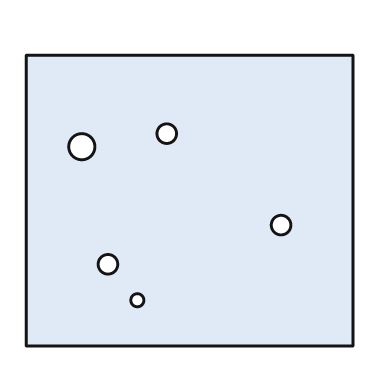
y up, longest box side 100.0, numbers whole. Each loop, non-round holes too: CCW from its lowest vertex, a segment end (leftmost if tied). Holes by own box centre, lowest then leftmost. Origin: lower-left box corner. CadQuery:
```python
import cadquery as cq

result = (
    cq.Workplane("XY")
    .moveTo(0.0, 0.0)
    .lineTo(100.0, 0.0)
    .lineTo(100.0, 89.0)
    .lineTo(0.0, 89.0)
    .close()
    .moveTo(34.0, 14.0)
    .circle(2.0)
    .moveTo(25.0, 25.0)
    .circle(3.0)
    .moveTo(78.0, 37.0)
    .circle(3.0)
    .moveTo(17.0, 61.0)
    .circle(4.0)
    .moveTo(43.0, 65.0)
    .circle(3.0)
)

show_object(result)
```